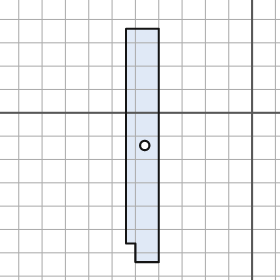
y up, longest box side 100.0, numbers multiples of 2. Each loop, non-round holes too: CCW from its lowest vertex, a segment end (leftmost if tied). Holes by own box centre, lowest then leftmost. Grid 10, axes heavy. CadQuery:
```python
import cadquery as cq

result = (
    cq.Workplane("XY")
    .moveTo(-50.0, -64.0)
    .lineTo(-40.0, -64.0)
    .lineTo(-40.0, 36.0)
    .lineTo(-54.0, 36.0)
    .lineTo(-54.0, -56.0)
    .lineTo(-50.0, -56.0)
    .close()
    .moveTo(-46.0, -14.0)
    .circle(2.0)
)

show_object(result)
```